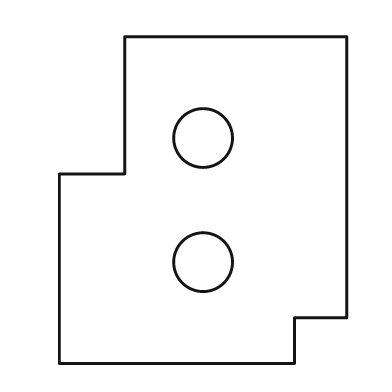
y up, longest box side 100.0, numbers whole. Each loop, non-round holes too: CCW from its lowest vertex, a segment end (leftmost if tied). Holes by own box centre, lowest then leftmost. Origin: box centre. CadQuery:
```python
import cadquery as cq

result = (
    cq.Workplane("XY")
    .moveTo(-44.0, -50.0)
    .lineTo(28.0, -50.0)
    .lineTo(28.0, -36.0)
    .lineTo(44.0, -36.0)
    .lineTo(44.0, 50.0)
    .lineTo(-24.0, 50.0)
    .lineTo(-24.0, 8.0)
    .lineTo(-44.0, 8.0)
    .close()
    .moveTo(0.0, -19.0)
    .circle(9.0)
    .moveTo(0.0, 19.0)
    .circle(9.0)
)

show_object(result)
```